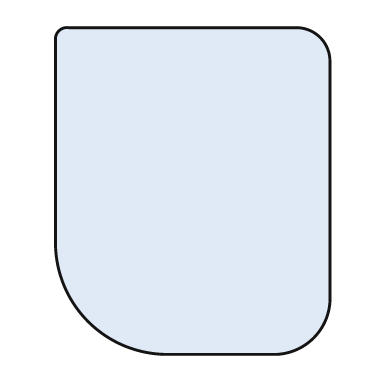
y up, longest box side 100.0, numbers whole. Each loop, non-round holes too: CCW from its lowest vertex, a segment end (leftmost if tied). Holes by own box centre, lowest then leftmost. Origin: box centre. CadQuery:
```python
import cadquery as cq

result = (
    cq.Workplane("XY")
    .moveTo(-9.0, -50.0)
    .lineTo(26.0, -50.0)
    .threePointArc((37.0, -45.0), (42.0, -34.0))
    .lineTo(42.0, 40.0)
    .threePointArc((39.0, 47.0), (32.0, 50.0))
    .lineTo(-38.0, 50.0)
    .threePointArc((-41.0, 49.0), (-42.0, 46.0))
    .lineTo(-42.0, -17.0)
    .threePointArc((-32.0, -40.0), (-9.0, -50.0))
    .close()
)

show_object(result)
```